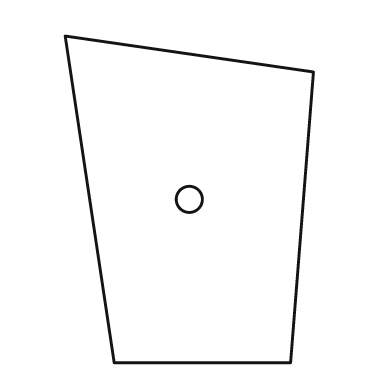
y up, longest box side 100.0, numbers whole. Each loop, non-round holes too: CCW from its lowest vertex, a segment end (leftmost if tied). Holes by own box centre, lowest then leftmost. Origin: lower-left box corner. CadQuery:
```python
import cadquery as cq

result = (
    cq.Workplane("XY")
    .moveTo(15.0, 0.0)
    .lineTo(69.0, 0.0)
    .lineTo(76.0, 89.0)
    .lineTo(0.0, 100.0)
    .close()
    .moveTo(38.0, 50.0)
    .circle(4.0)
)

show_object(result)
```